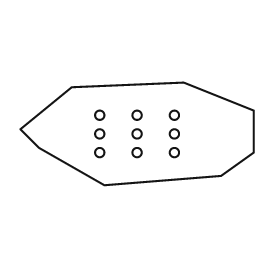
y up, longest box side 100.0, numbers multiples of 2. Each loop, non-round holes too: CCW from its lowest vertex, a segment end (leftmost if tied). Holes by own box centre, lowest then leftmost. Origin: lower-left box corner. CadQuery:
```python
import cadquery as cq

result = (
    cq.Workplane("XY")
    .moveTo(36.0, 0.0)
    .lineTo(86.0, 4.0)
    .lineTo(100.0, 14.0)
    .lineTo(100.0, 32.0)
    .lineTo(70.0, 44.0)
    .lineTo(22.0, 42.0)
    .lineTo(0.0, 24.0)
    .lineTo(8.0, 16.0)
    .close()
    .moveTo(34.0, 14.0)
    .circle(2.0)
    .moveTo(50.0, 14.0)
    .circle(2.0)
    .moveTo(66.0, 14.0)
    .circle(2.0)
    .moveTo(34.0, 22.0)
    .circle(2.0)
    .moveTo(50.0, 22.0)
    .circle(2.0)
    .moveTo(66.0, 22.0)
    .circle(2.0)
    .moveTo(34.0, 30.0)
    .circle(2.0)
    .moveTo(50.0, 30.0)
    .circle(2.0)
    .moveTo(66.0, 30.0)
    .circle(2.0)
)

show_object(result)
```